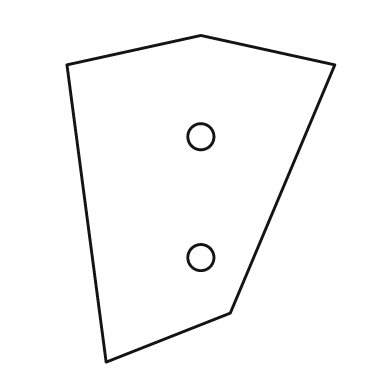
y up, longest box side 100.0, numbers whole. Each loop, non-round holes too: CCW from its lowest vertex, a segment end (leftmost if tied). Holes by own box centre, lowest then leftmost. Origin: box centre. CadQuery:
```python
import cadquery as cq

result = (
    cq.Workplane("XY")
    .moveTo(-29.0, -50.0)
    .lineTo(9.0, -35.0)
    .lineTo(41.0, 41.0)
    .lineTo(0.0, 50.0)
    .lineTo(-41.0, 41.0)
    .close()
    .moveTo(0.0, -18.0)
    .circle(4.0)
    .moveTo(0.0, 19.0)
    .circle(4.0)
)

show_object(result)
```